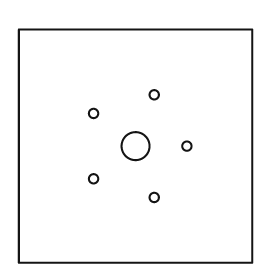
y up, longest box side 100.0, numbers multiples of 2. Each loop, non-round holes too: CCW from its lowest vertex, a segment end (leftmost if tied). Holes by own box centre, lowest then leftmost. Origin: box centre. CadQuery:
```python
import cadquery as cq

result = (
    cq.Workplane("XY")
    .moveTo(-50.0, -50.0)
    .lineTo(50.0, -50.0)
    .lineTo(50.0, 50.0)
    .lineTo(-50.0, 50.0)
    .close()
    .moveTo(8.0, -22.0)
    .circle(2.0)
    .moveTo(-18.0, -14.0)
    .circle(2.0)
    .moveTo(0.0, 0.0)
    .circle(6.0)
    .moveTo(22.0, 0.0)
    .circle(2.0)
    .moveTo(-18.0, 14.0)
    .circle(2.0)
    .moveTo(8.0, 22.0)
    .circle(2.0)
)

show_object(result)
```